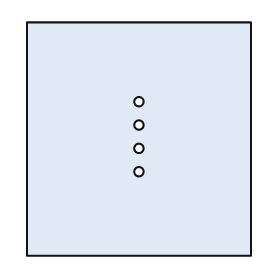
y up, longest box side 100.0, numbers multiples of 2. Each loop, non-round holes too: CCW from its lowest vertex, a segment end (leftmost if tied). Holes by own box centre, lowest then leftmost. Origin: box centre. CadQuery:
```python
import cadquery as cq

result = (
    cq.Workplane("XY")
    .moveTo(-48.0, -50.0)
    .lineTo(48.0, -50.0)
    .lineTo(48.0, 50.0)
    .lineTo(-48.0, 50.0)
    .close()
    .moveTo(0.0, -14.0)
    .circle(2.0)
    .moveTo(0.0, -4.0)
    .circle(2.0)
    .moveTo(0.0, 6.0)
    .circle(2.0)
    .moveTo(0.0, 16.0)
    .circle(2.0)
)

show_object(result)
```